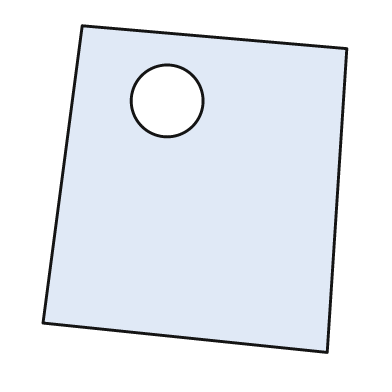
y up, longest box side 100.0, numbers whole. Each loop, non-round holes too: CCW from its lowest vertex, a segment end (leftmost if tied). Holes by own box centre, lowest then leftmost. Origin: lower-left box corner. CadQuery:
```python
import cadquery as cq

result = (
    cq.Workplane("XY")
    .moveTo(87.0, 0.0)
    .lineTo(93.0, 93.0)
    .lineTo(12.0, 100.0)
    .lineTo(0.0, 9.0)
    .close()
    .moveTo(38.0, 77.0)
    .circle(11.0)
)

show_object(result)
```